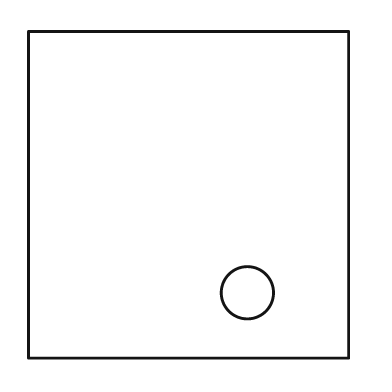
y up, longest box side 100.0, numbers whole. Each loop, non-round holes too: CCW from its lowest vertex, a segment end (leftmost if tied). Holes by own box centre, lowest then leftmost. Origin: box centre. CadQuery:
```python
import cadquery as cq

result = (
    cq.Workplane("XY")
    .moveTo(-49.0, -50.0)
    .lineTo(49.0, -50.0)
    .lineTo(49.0, 50.0)
    .lineTo(-49.0, 50.0)
    .close()
    .moveTo(18.0, -30.0)
    .circle(8.0)
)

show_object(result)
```